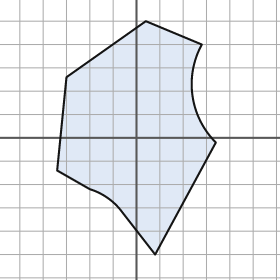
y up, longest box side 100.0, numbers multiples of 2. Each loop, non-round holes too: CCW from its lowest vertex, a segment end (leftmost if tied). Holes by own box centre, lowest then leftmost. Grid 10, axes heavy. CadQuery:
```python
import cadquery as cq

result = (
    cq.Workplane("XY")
    .moveTo(8.0, -50.0)
    .lineTo(34.0, -2.0)
    .threePointArc((24.0, 18.0), (28.0, 40.0))
    .lineTo(4.0, 50.0)
    .lineTo(-30.0, 26.0)
    .lineTo(-34.0, -14.0)
    .lineTo(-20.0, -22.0)
    .threePointArc((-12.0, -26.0), (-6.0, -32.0))
    .close()
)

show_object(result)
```